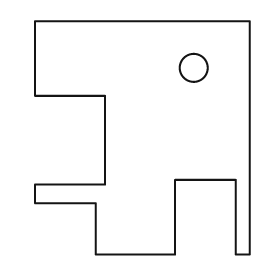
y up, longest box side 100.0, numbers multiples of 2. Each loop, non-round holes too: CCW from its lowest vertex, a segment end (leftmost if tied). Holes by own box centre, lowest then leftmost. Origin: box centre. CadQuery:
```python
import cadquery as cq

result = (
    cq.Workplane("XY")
    .moveTo(-20.0, -50.0)
    .lineTo(14.0, -50.0)
    .lineTo(14.0, -18.0)
    .lineTo(40.0, -18.0)
    .lineTo(40.0, -50.0)
    .lineTo(46.0, -50.0)
    .lineTo(46.0, 50.0)
    .lineTo(-46.0, 50.0)
    .lineTo(-46.0, 18.0)
    .lineTo(-16.0, 18.0)
    .lineTo(-16.0, -20.0)
    .lineTo(-46.0, -20.0)
    .lineTo(-46.0, -28.0)
    .lineTo(-20.0, -28.0)
    .close()
    .moveTo(22.0, 30.0)
    .circle(6.0)
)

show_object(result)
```